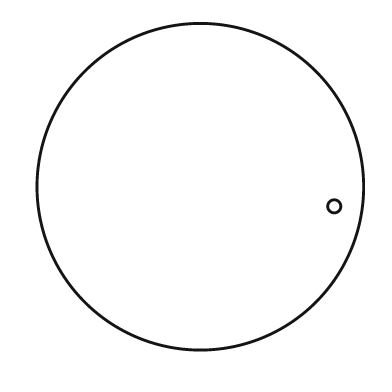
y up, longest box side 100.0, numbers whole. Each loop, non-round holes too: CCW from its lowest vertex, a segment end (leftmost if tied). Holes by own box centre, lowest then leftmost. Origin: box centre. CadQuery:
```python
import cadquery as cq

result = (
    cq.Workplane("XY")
    .moveTo(0.0, 0.0)
    .circle(50.0)
    .moveTo(41.0, -6.0)
    .circle(2.0)
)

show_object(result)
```